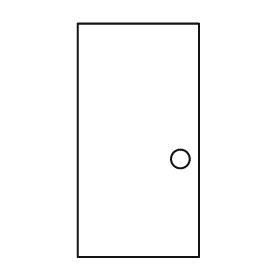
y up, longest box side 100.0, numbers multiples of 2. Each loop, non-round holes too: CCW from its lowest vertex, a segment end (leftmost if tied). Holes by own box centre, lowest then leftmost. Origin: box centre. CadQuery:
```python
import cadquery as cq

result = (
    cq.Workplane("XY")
    .moveTo(-26.0, -50.0)
    .lineTo(26.0, -50.0)
    .lineTo(26.0, 50.0)
    .lineTo(-26.0, 50.0)
    .close()
    .moveTo(18.0, -8.0)
    .circle(4.0)
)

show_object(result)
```